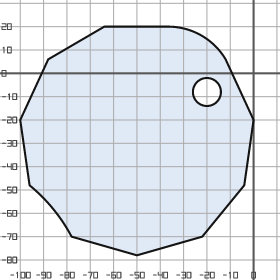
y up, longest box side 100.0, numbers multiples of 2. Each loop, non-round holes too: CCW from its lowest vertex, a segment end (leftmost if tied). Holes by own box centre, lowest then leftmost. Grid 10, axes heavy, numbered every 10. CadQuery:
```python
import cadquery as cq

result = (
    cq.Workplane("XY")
    .moveTo(-50.0, -78.0)
    .lineTo(-22.0, -70.0)
    .lineTo(-4.0, -48.0)
    .lineTo(0.0, -20.0)
    .lineTo(-12.0, 6.0)
    .threePointArc((-22.0, 16.0), (-36.0, 20.0))
    .lineTo(-64.0, 20.0)
    .lineTo(-88.0, 6.0)
    .lineTo(-100.0, -20.0)
    .lineTo(-96.0, -48.0)
    .threePointArc((-86.0, -58.0), (-78.0, -70.0))
    .close()
    .moveTo(-20.0, -8.0)
    .circle(6.0)
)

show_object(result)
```